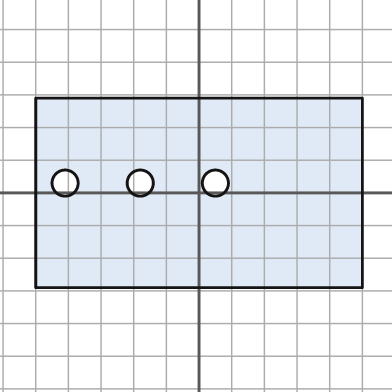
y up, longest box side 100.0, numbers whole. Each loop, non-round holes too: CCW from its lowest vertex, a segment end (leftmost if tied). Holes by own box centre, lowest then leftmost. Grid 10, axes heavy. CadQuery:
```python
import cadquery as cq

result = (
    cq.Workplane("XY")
    .moveTo(-50.0, -29.0)
    .lineTo(50.0, -29.0)
    .lineTo(50.0, 29.0)
    .lineTo(-50.0, 29.0)
    .close()
    .moveTo(-41.0, 3.0)
    .circle(4.0)
    .moveTo(-18.0, 3.0)
    .circle(4.0)
    .moveTo(5.0, 3.0)
    .circle(4.0)
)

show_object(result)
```